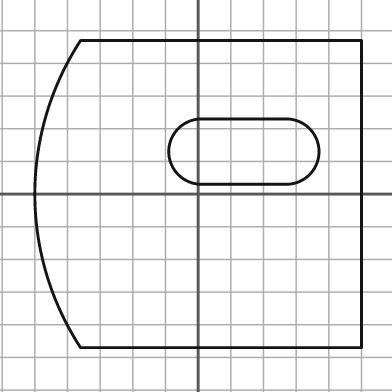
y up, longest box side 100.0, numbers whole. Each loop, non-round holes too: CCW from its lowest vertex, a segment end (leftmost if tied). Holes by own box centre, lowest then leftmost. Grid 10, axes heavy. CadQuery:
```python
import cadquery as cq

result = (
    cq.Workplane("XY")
    .moveTo(-36.0, -47.0)
    .lineTo(50.0, -47.0)
    .lineTo(50.0, 47.0)
    .lineTo(-36.0, 47.0)
    .threePointArc((-50.0, 0.0), (-36.0, -47.0))
    .close()
    .moveTo(1.0, 3.0)
    .lineTo(27.0, 3.0)
    .threePointArc((37.0, 13.0), (27.0, 23.0))
    .lineTo(1.0, 23.0)
    .threePointArc((-9.0, 13.0), (1.0, 3.0))
    .close()
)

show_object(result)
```